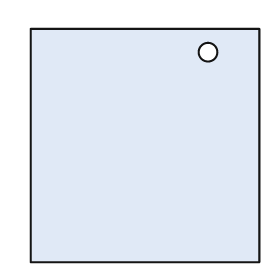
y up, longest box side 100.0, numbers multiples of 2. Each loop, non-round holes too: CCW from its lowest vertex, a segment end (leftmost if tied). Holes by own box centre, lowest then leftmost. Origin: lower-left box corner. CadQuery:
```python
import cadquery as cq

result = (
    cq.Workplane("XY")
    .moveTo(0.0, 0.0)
    .lineTo(98.0, 0.0)
    .lineTo(98.0, 100.0)
    .lineTo(0.0, 100.0)
    .close()
    .moveTo(76.0, 90.0)
    .circle(4.0)
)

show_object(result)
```